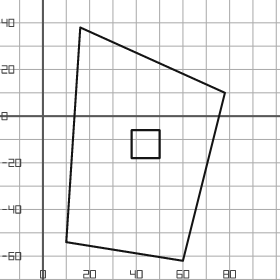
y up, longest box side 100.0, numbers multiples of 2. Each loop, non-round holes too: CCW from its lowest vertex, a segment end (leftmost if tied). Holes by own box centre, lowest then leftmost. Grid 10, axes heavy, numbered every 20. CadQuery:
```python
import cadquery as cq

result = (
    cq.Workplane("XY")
    .moveTo(60.0, -62.0)
    .lineTo(78.0, 10.0)
    .lineTo(16.0, 38.0)
    .lineTo(10.0, -54.0)
    .close()
    .moveTo(38.0, -18.0)
    .lineTo(50.0, -18.0)
    .lineTo(50.0, -6.0)
    .lineTo(38.0, -6.0)
    .close()
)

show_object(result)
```